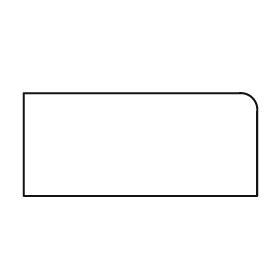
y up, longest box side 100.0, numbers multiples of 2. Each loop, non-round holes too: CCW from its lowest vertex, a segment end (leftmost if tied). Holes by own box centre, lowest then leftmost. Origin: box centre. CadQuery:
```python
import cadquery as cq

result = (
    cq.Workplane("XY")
    .moveTo(-50.0, -22.0)
    .lineTo(50.0, -22.0)
    .lineTo(50.0, 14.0)
    .threePointArc((48.0, 20.0), (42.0, 22.0))
    .lineTo(-50.0, 22.0)
    .close()
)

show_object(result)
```